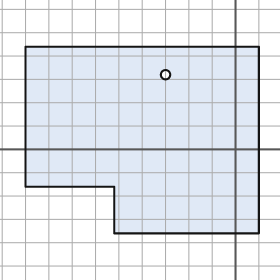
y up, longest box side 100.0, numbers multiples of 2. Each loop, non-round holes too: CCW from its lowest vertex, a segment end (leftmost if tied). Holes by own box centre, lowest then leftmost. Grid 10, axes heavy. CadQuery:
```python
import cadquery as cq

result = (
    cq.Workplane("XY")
    .moveTo(-52.0, -36.0)
    .lineTo(10.0, -36.0)
    .lineTo(10.0, 44.0)
    .lineTo(-90.0, 44.0)
    .lineTo(-90.0, -16.0)
    .lineTo(-52.0, -16.0)
    .close()
    .moveTo(-30.0, 32.0)
    .circle(2.0)
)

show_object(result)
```